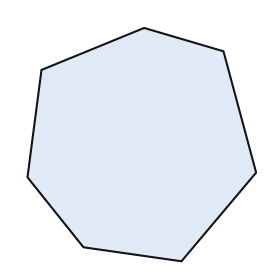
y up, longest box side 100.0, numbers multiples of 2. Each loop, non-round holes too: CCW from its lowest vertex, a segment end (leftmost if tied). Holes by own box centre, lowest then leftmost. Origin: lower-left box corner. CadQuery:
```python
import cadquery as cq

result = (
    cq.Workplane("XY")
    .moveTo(66.0, 0.0)
    .lineTo(98.0, 38.0)
    .lineTo(84.0, 90.0)
    .lineTo(50.0, 100.0)
    .lineTo(6.0, 82.0)
    .lineTo(0.0, 36.0)
    .lineTo(24.0, 6.0)
    .close()
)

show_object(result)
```